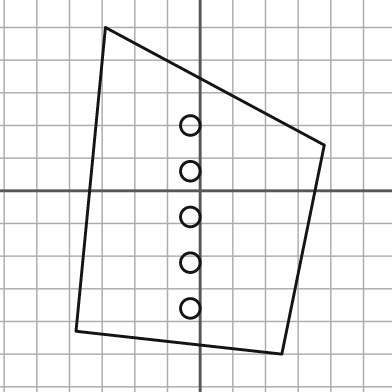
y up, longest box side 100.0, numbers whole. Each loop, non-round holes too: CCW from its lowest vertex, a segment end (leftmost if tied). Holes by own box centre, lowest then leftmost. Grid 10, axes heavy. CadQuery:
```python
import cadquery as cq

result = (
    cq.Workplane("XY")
    .moveTo(25.0, -50.0)
    .lineTo(38.0, 14.0)
    .lineTo(-29.0, 50.0)
    .lineTo(-38.0, -43.0)
    .close()
    .moveTo(-3.0, -36.0)
    .circle(3.0)
    .moveTo(-3.0, -22.0)
    .circle(3.0)
    .moveTo(-3.0, -8.0)
    .circle(3.0)
    .moveTo(-3.0, 6.0)
    .circle(3.0)
    .moveTo(-3.0, 20.0)
    .circle(3.0)
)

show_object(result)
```